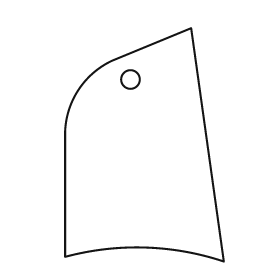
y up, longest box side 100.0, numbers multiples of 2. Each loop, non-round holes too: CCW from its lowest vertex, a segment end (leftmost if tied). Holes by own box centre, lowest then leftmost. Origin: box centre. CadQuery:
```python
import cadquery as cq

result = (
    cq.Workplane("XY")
    .moveTo(34.0, -50.0)
    .lineTo(20.0, 50.0)
    .lineTo(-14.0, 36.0)
    .threePointArc((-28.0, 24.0), (-34.0, 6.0))
    .lineTo(-34.0, -48.0)
    .threePointArc((0.0, -44.0), (34.0, -50.0))
    .close()
    .moveTo(-6.0, 28.0)
    .circle(4.0)
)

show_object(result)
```